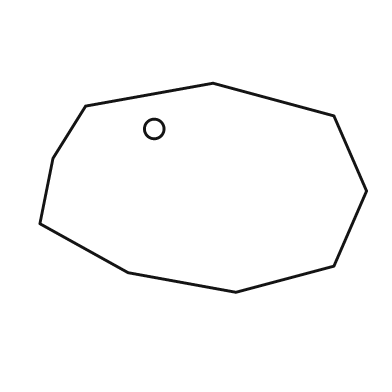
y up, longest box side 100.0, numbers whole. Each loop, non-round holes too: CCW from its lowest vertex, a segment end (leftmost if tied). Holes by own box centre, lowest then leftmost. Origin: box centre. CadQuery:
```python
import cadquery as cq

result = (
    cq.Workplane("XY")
    .moveTo(10.0, -32.0)
    .lineTo(40.0, -24.0)
    .lineTo(50.0, -1.0)
    .lineTo(40.0, 22.0)
    .lineTo(3.0, 32.0)
    .lineTo(-36.0, 25.0)
    .lineTo(-46.0, 9.0)
    .lineTo(-50.0, -11.0)
    .lineTo(-23.0, -26.0)
    .close()
    .moveTo(-15.0, 18.0)
    .circle(3.0)
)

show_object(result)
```